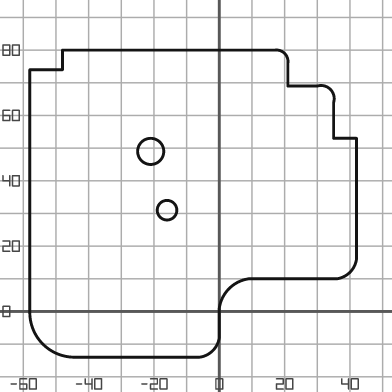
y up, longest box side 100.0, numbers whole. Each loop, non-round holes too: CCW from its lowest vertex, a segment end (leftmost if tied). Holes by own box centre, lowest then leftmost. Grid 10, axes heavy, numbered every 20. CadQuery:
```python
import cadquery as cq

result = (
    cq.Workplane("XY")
    .moveTo(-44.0, -14.0)
    .lineTo(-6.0, -14.0)
    .threePointArc((-2.0, -12.0), (0.0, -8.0))
    .lineTo(0.0, 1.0)
    .threePointArc((3.0, 7.0), (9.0, 10.0))
    .lineTo(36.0, 10.0)
    .threePointArc((40.0, 12.0), (42.0, 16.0))
    .lineTo(42.0, 53.0)
    .lineTo(35.0, 53.0)
    .lineTo(35.0, 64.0)
    .threePointArc((34.0, 68.0), (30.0, 69.0))
    .lineTo(21.0, 69.0)
    .lineTo(21.0, 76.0)
    .threePointArc((20.0, 79.0), (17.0, 80.0))
    .lineTo(-48.0, 80.0)
    .lineTo(-48.0, 74.0)
    .lineTo(-58.0, 74.0)
    .lineTo(-58.0, 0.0)
    .threePointArc((-54.0, -10.0), (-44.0, -14.0))
    .close()
    .moveTo(-16.0, 31.0)
    .circle(3.0)
    .moveTo(-21.0, 49.0)
    .circle(4.0)
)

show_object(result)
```